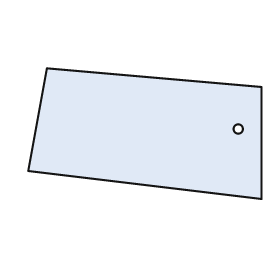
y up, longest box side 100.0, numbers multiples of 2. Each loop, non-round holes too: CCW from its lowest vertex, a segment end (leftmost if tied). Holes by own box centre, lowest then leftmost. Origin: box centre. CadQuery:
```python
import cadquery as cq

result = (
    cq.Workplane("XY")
    .moveTo(50.0, -28.0)
    .lineTo(50.0, 20.0)
    .lineTo(-42.0, 28.0)
    .lineTo(-50.0, -16.0)
    .close()
    .moveTo(40.0, 2.0)
    .circle(2.0)
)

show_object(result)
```